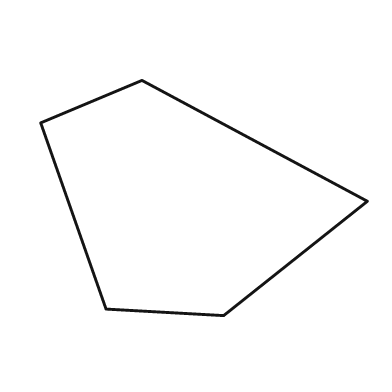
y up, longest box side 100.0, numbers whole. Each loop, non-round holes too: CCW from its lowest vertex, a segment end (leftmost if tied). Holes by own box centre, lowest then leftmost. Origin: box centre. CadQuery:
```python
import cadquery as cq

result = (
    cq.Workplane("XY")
    .moveTo(6.0, -36.0)
    .lineTo(50.0, -1.0)
    .lineTo(-19.0, 36.0)
    .lineTo(-50.0, 23.0)
    .lineTo(-30.0, -34.0)
    .close()
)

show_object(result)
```